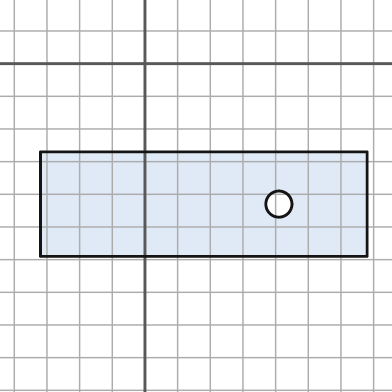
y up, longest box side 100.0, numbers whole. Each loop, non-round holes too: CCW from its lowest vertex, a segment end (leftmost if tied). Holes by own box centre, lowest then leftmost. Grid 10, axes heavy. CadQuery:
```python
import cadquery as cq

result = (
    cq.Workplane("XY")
    .moveTo(-32.0, -59.0)
    .lineTo(68.0, -59.0)
    .lineTo(68.0, -27.0)
    .lineTo(-32.0, -27.0)
    .close()
    .moveTo(41.0, -43.0)
    .circle(4.0)
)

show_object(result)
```